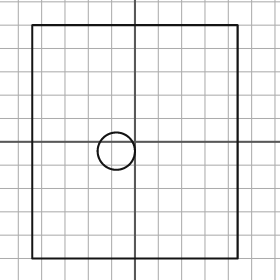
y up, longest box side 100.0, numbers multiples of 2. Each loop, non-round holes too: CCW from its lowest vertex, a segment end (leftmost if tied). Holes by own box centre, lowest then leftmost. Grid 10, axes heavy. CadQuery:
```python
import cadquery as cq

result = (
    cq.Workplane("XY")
    .moveTo(-44.0, -50.0)
    .lineTo(44.0, -50.0)
    .lineTo(44.0, 50.0)
    .lineTo(-44.0, 50.0)
    .close()
    .moveTo(-8.0, -4.0)
    .circle(8.0)
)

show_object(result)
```